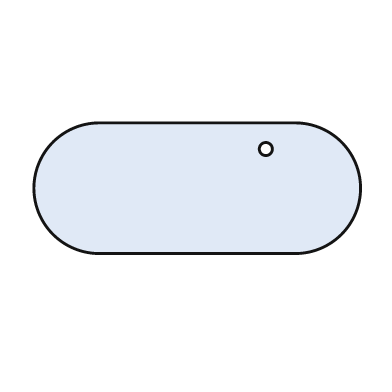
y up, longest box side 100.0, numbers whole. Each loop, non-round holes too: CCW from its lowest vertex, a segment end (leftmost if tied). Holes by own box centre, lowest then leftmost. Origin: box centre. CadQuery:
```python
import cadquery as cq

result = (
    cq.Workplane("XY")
    .moveTo(-30.0, -20.0)
    .lineTo(30.0, -20.0)
    .threePointArc((50.0, 0.0), (30.0, 20.0))
    .lineTo(-30.0, 20.0)
    .threePointArc((-50.0, 0.0), (-30.0, -20.0))
    .close()
    .moveTo(21.0, 12.0)
    .circle(2.0)
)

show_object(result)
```